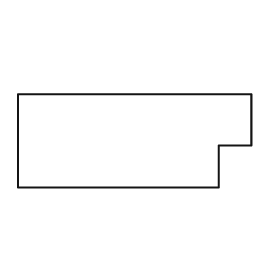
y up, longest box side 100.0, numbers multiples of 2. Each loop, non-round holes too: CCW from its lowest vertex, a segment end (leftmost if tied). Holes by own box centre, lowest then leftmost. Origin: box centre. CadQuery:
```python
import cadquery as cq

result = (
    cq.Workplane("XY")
    .moveTo(-50.0, -20.0)
    .lineTo(36.0, -20.0)
    .lineTo(36.0, -2.0)
    .lineTo(50.0, -2.0)
    .lineTo(50.0, 20.0)
    .lineTo(-50.0, 20.0)
    .close()
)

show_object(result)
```